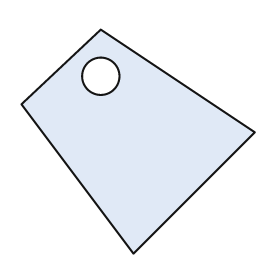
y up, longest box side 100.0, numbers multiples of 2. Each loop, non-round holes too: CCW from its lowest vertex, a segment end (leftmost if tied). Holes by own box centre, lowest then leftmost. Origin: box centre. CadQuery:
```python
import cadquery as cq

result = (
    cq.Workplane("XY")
    .moveTo(-2.0, -48.0)
    .lineTo(50.0, 4.0)
    .lineTo(-16.0, 48.0)
    .lineTo(-50.0, 16.0)
    .close()
    .moveTo(-16.0, 28.0)
    .circle(8.0)
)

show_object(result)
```